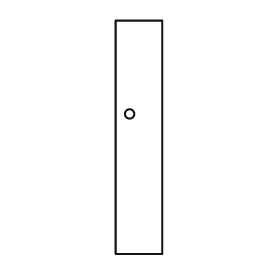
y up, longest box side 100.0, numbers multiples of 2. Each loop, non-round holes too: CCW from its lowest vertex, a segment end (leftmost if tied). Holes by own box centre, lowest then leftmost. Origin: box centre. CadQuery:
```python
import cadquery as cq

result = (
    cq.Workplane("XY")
    .moveTo(-10.0, -50.0)
    .lineTo(10.0, -50.0)
    .lineTo(10.0, 50.0)
    .lineTo(-10.0, 50.0)
    .close()
    .moveTo(-4.0, 10.0)
    .circle(2.0)
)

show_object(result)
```